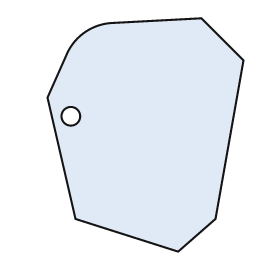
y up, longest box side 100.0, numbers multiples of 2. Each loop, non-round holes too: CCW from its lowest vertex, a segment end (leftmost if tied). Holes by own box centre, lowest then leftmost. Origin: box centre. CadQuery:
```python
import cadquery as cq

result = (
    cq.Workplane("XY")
    .moveTo(14.0, -50.0)
    .lineTo(30.0, -36.0)
    .lineTo(42.0, 32.0)
    .lineTo(24.0, 50.0)
    .lineTo(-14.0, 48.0)
    .threePointArc((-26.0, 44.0), (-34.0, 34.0))
    .lineTo(-42.0, 16.0)
    .lineTo(-30.0, -36.0)
    .close()
    .moveTo(-32.0, 8.0)
    .circle(4.0)
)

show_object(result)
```